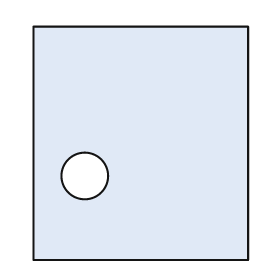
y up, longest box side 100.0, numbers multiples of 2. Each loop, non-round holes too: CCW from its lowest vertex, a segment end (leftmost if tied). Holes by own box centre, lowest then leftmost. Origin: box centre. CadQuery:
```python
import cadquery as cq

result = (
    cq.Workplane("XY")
    .moveTo(-46.0, -50.0)
    .lineTo(46.0, -50.0)
    .lineTo(46.0, 50.0)
    .lineTo(-46.0, 50.0)
    .close()
    .moveTo(-24.0, -14.0)
    .circle(10.0)
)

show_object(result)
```